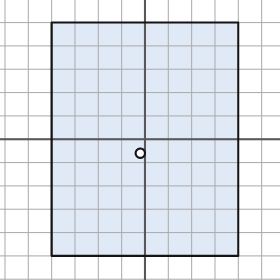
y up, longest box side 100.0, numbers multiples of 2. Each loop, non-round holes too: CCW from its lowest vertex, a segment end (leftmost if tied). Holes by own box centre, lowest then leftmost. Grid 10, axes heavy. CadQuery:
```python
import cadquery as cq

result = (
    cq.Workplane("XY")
    .moveTo(-40.0, -50.0)
    .lineTo(40.0, -50.0)
    .lineTo(40.0, 50.0)
    .lineTo(-40.0, 50.0)
    .close()
    .moveTo(-2.0, -6.0)
    .circle(2.0)
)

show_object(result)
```